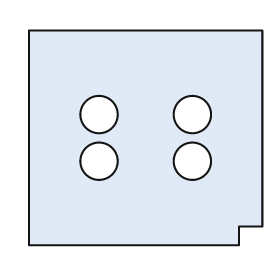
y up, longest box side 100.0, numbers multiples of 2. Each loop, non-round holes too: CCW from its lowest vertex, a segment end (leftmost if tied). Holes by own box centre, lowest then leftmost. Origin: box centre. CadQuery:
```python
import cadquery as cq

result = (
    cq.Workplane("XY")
    .moveTo(-50.0, -46.0)
    .lineTo(40.0, -46.0)
    .lineTo(40.0, -38.0)
    .lineTo(50.0, -38.0)
    .lineTo(50.0, 46.0)
    .lineTo(-50.0, 46.0)
    .close()
    .moveTo(-20.0, -10.0)
    .circle(8.0)
    .moveTo(20.0, -10.0)
    .circle(8.0)
    .moveTo(-20.0, 10.0)
    .circle(8.0)
    .moveTo(20.0, 10.0)
    .circle(8.0)
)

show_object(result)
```